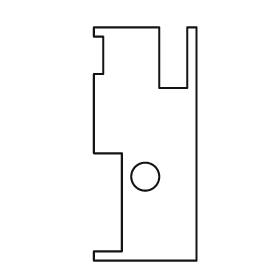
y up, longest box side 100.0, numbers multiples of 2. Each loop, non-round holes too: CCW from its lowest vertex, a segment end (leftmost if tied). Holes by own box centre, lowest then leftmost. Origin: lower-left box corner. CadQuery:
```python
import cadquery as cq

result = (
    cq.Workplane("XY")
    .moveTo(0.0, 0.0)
    .lineTo(44.0, 0.0)
    .lineTo(44.0, 100.0)
    .lineTo(40.0, 100.0)
    .lineTo(40.0, 74.0)
    .lineTo(28.0, 74.0)
    .lineTo(28.0, 100.0)
    .lineTo(0.0, 100.0)
    .lineTo(0.0, 96.0)
    .lineTo(4.0, 96.0)
    .lineTo(4.0, 80.0)
    .lineTo(0.0, 80.0)
    .lineTo(0.0, 46.0)
    .lineTo(12.0, 46.0)
    .lineTo(12.0, 4.0)
    .lineTo(0.0, 4.0)
    .close()
    .moveTo(22.0, 36.0)
    .circle(6.0)
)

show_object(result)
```